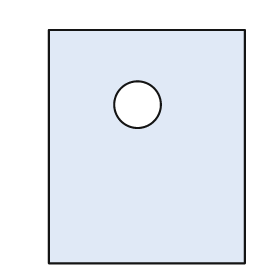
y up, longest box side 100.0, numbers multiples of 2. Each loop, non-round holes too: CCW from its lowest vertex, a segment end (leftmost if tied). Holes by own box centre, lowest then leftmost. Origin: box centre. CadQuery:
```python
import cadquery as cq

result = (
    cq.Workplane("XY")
    .moveTo(-42.0, -50.0)
    .lineTo(42.0, -50.0)
    .lineTo(42.0, 50.0)
    .lineTo(-42.0, 50.0)
    .close()
    .moveTo(-4.0, 18.0)
    .circle(10.0)
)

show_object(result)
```